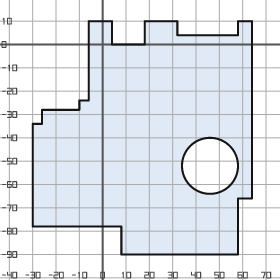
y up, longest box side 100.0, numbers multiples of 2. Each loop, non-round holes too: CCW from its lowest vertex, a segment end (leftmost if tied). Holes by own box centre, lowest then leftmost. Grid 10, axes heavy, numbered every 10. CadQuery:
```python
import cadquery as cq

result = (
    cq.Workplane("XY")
    .moveTo(8.0, -90.0)
    .lineTo(58.0, -90.0)
    .lineTo(58.0, -66.0)
    .lineTo(64.0, -66.0)
    .lineTo(64.0, 10.0)
    .lineTo(58.0, 10.0)
    .lineTo(58.0, 4.0)
    .lineTo(32.0, 4.0)
    .lineTo(32.0, 10.0)
    .lineTo(18.0, 10.0)
    .lineTo(18.0, 0.0)
    .lineTo(4.0, 0.0)
    .lineTo(4.0, 10.0)
    .lineTo(-6.0, 10.0)
    .lineTo(-6.0, -24.0)
    .lineTo(-10.0, -24.0)
    .lineTo(-10.0, -28.0)
    .lineTo(-26.0, -28.0)
    .lineTo(-26.0, -34.0)
    .lineTo(-30.0, -34.0)
    .lineTo(-30.0, -78.0)
    .lineTo(8.0, -78.0)
    .close()
    .moveTo(46.0, -52.0)
    .circle(12.0)
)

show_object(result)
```